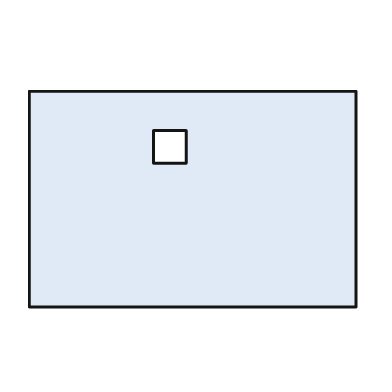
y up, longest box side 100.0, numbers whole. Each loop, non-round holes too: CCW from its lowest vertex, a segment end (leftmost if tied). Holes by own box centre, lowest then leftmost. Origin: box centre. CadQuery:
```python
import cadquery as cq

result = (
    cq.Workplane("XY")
    .moveTo(-50.0, -33.0)
    .lineTo(50.0, -33.0)
    .lineTo(50.0, 33.0)
    .lineTo(-50.0, 33.0)
    .close()
    .moveTo(-12.0, 11.0)
    .lineTo(-2.0, 11.0)
    .lineTo(-2.0, 21.0)
    .lineTo(-12.0, 21.0)
    .close()
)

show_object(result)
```